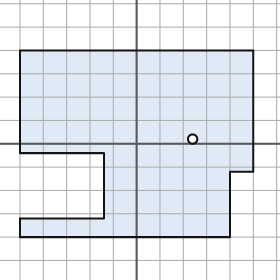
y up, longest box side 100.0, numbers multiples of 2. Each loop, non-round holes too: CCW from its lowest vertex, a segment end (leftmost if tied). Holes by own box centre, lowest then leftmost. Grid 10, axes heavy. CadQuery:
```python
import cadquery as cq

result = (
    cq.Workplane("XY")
    .moveTo(-50.0, -40.0)
    .lineTo(40.0, -40.0)
    .lineTo(40.0, -12.0)
    .lineTo(50.0, -12.0)
    .lineTo(50.0, 40.0)
    .lineTo(-50.0, 40.0)
    .lineTo(-50.0, -4.0)
    .lineTo(-14.0, -4.0)
    .lineTo(-14.0, -32.0)
    .lineTo(-50.0, -32.0)
    .close()
    .moveTo(24.0, 2.0)
    .circle(2.0)
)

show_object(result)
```